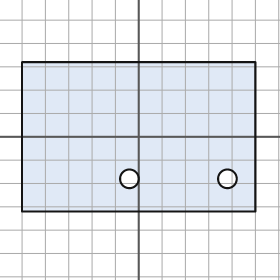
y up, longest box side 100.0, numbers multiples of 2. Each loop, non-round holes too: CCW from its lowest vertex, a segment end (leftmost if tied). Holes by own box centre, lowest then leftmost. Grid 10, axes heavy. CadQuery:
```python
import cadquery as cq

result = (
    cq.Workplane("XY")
    .moveTo(-50.0, -32.0)
    .lineTo(50.0, -32.0)
    .lineTo(50.0, 32.0)
    .lineTo(-50.0, 32.0)
    .close()
    .moveTo(-4.0, -18.0)
    .circle(4.0)
    .moveTo(38.0, -18.0)
    .circle(4.0)
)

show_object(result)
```